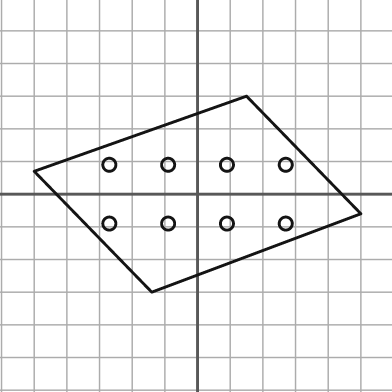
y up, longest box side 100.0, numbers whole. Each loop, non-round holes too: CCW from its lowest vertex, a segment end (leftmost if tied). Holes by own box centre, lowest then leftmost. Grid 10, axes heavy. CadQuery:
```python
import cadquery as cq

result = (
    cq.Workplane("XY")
    .moveTo(-14.0, -30.0)
    .lineTo(50.0, -6.0)
    .lineTo(15.0, 30.0)
    .lineTo(-50.0, 7.0)
    .close()
    .moveTo(-27.0, -9.0)
    .circle(2.0)
    .moveTo(-9.0, -9.0)
    .circle(2.0)
    .moveTo(9.0, -9.0)
    .circle(2.0)
    .moveTo(27.0, -9.0)
    .circle(2.0)
    .moveTo(-27.0, 9.0)
    .circle(2.0)
    .moveTo(-9.0, 9.0)
    .circle(2.0)
    .moveTo(9.0, 9.0)
    .circle(2.0)
    .moveTo(27.0, 9.0)
    .circle(2.0)
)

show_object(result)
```